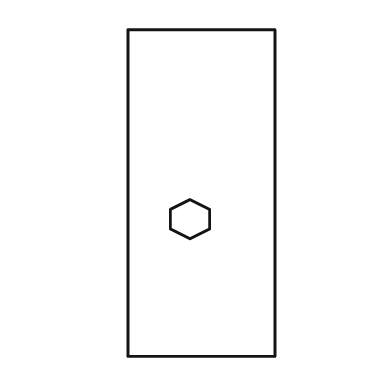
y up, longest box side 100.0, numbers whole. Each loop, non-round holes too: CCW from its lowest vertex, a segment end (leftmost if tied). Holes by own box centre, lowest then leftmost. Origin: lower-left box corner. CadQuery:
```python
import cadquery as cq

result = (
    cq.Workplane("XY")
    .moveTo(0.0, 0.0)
    .lineTo(45.0, 0.0)
    .lineTo(45.0, 100.0)
    .lineTo(0.0, 100.0)
    .close()
    .moveTo(19.0, 36.0)
    .lineTo(25.0, 39.0)
    .lineTo(25.0, 45.0)
    .lineTo(19.0, 48.0)
    .lineTo(13.0, 45.0)
    .lineTo(13.0, 39.0)
    .close()
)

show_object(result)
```